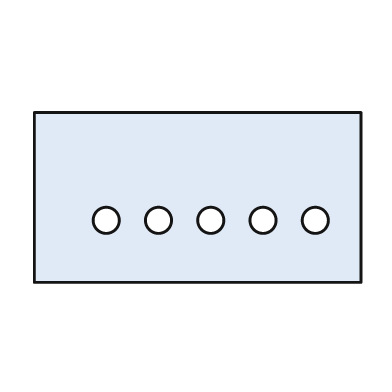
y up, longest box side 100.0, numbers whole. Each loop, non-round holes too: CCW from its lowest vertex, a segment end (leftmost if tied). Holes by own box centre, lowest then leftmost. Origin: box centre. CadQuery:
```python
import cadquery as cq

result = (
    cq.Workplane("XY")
    .moveTo(-50.0, -26.0)
    .lineTo(50.0, -26.0)
    .lineTo(50.0, 26.0)
    .lineTo(-50.0, 26.0)
    .close()
    .moveTo(-28.0, -7.0)
    .circle(4.0)
    .moveTo(-12.0, -7.0)
    .circle(4.0)
    .moveTo(4.0, -7.0)
    .circle(4.0)
    .moveTo(20.0, -7.0)
    .circle(4.0)
    .moveTo(36.0, -7.0)
    .circle(4.0)
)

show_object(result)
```